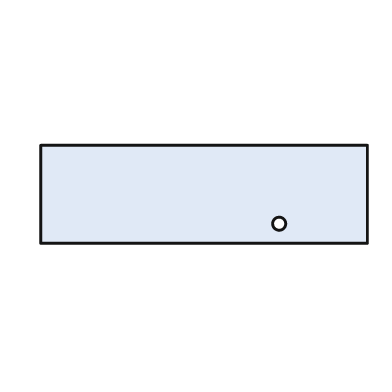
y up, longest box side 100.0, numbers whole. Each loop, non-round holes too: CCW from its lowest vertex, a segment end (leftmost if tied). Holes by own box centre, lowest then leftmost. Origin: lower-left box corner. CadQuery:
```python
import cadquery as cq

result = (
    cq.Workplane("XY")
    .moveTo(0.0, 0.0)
    .lineTo(100.0, 0.0)
    .lineTo(100.0, 30.0)
    .lineTo(0.0, 30.0)
    .close()
    .moveTo(73.0, 6.0)
    .circle(2.0)
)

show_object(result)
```